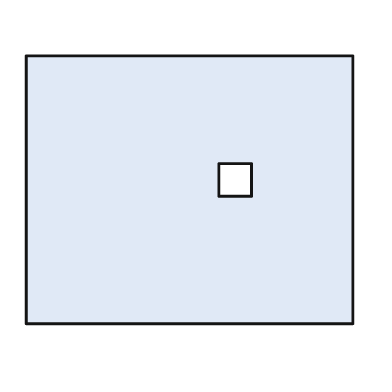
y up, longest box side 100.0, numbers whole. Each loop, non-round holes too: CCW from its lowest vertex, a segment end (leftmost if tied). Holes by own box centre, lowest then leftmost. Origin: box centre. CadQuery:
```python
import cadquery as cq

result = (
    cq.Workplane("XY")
    .moveTo(-50.0, -41.0)
    .lineTo(50.0, -41.0)
    .lineTo(50.0, 41.0)
    .lineTo(-50.0, 41.0)
    .close()
    .moveTo(9.0, -2.0)
    .lineTo(19.0, -2.0)
    .lineTo(19.0, 8.0)
    .lineTo(9.0, 8.0)
    .close()
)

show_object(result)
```